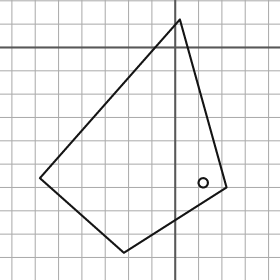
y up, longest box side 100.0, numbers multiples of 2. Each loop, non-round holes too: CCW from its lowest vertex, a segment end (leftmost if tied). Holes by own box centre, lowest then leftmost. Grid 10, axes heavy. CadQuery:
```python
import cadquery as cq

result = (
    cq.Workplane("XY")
    .moveTo(-22.0, -88.0)
    .lineTo(22.0, -60.0)
    .lineTo(2.0, 12.0)
    .lineTo(-58.0, -56.0)
    .close()
    .moveTo(12.0, -58.0)
    .circle(2.0)
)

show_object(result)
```